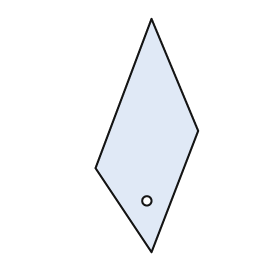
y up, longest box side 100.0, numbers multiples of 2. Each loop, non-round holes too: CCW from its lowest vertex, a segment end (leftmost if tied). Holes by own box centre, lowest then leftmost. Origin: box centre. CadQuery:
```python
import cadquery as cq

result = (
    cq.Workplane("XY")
    .moveTo(2.0, -50.0)
    .lineTo(22.0, 2.0)
    .lineTo(2.0, 50.0)
    .lineTo(-22.0, -14.0)
    .close()
    .moveTo(0.0, -28.0)
    .circle(2.0)
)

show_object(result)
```